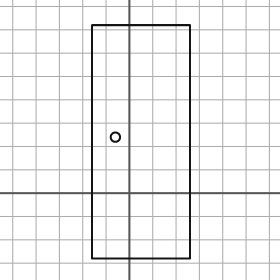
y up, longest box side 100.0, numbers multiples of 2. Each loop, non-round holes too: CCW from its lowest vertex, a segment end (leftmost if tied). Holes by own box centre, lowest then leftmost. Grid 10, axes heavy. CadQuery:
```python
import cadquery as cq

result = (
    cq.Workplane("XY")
    .moveTo(-16.0, -28.0)
    .lineTo(26.0, -28.0)
    .lineTo(26.0, 72.0)
    .lineTo(-16.0, 72.0)
    .close()
    .moveTo(-6.0, 24.0)
    .circle(2.0)
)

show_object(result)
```